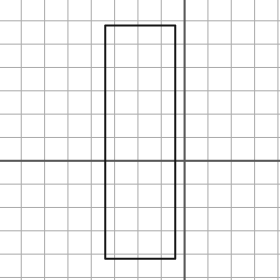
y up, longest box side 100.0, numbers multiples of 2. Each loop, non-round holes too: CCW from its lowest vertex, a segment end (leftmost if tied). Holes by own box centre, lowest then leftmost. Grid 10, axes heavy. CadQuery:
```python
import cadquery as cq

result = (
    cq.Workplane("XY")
    .moveTo(-34.0, -42.0)
    .lineTo(-4.0, -42.0)
    .lineTo(-4.0, 58.0)
    .lineTo(-34.0, 58.0)
    .close()
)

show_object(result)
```